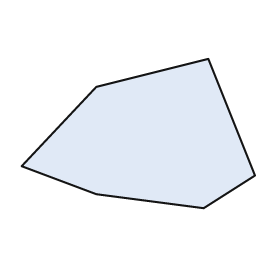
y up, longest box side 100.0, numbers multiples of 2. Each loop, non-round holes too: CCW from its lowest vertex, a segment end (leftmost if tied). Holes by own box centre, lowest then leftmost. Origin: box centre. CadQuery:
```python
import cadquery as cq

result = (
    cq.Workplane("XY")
    .moveTo(28.0, -32.0)
    .lineTo(50.0, -18.0)
    .lineTo(30.0, 32.0)
    .lineTo(-18.0, 20.0)
    .lineTo(-50.0, -14.0)
    .lineTo(-18.0, -26.0)
    .close()
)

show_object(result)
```